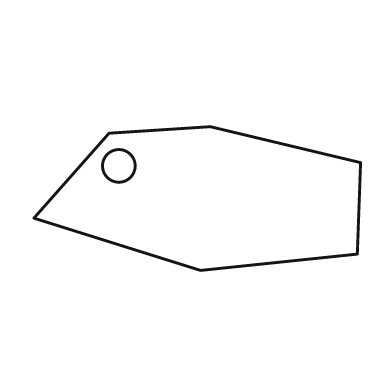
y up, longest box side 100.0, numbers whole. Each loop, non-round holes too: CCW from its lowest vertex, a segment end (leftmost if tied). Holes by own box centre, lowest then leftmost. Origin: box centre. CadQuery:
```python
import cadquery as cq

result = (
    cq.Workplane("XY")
    .moveTo(1.0, -22.0)
    .lineTo(49.0, -17.0)
    .lineTo(50.0, 11.0)
    .lineTo(4.0, 22.0)
    .lineTo(-27.0, 20.0)
    .lineTo(-50.0, -6.0)
    .close()
    .moveTo(-24.0, 10.0)
    .circle(5.0)
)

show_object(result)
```